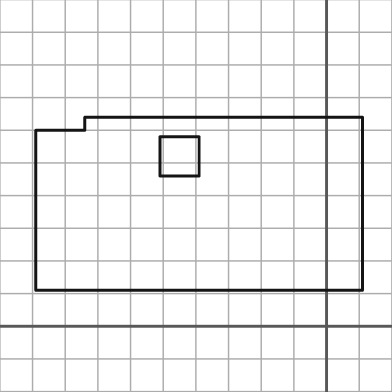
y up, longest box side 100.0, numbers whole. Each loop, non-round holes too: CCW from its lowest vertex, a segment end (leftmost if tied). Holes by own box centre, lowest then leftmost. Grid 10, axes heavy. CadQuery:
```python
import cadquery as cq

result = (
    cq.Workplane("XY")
    .moveTo(-89.0, 11.0)
    .lineTo(11.0, 11.0)
    .lineTo(11.0, 64.0)
    .lineTo(-74.0, 64.0)
    .lineTo(-74.0, 60.0)
    .lineTo(-89.0, 60.0)
    .close()
    .moveTo(-51.0, 46.0)
    .lineTo(-39.0, 46.0)
    .lineTo(-39.0, 58.0)
    .lineTo(-51.0, 58.0)
    .close()
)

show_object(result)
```